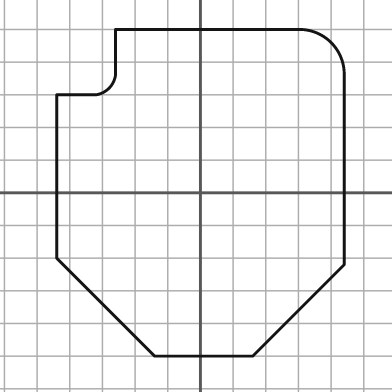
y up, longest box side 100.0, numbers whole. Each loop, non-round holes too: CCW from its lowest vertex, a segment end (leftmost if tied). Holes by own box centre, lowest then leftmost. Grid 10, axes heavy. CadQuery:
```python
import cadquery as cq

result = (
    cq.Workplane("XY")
    .moveTo(-14.0, -50.0)
    .lineTo(16.0, -50.0)
    .lineTo(44.0, -22.0)
    .lineTo(44.0, 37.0)
    .threePointArc((40.0, 46.0), (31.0, 50.0))
    .lineTo(-26.0, 50.0)
    .lineTo(-26.0, 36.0)
    .threePointArc((-28.0, 32.0), (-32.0, 30.0))
    .lineTo(-44.0, 30.0)
    .lineTo(-44.0, -20.0)
    .close()
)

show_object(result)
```